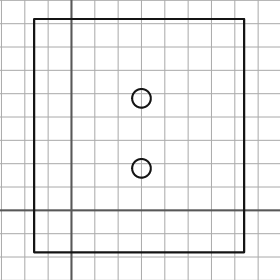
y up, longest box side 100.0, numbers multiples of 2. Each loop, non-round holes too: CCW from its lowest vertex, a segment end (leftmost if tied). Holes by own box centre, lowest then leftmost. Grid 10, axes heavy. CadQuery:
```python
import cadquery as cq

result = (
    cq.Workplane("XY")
    .moveTo(-16.0, -18.0)
    .lineTo(74.0, -18.0)
    .lineTo(74.0, 82.0)
    .lineTo(-16.0, 82.0)
    .close()
    .moveTo(30.0, 18.0)
    .circle(4.0)
    .moveTo(30.0, 48.0)
    .circle(4.0)
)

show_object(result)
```